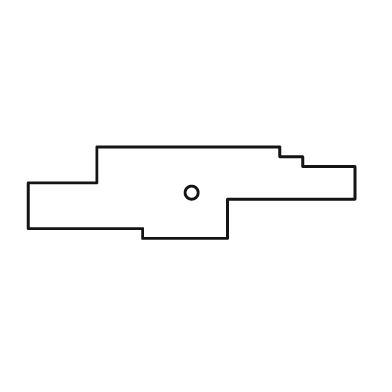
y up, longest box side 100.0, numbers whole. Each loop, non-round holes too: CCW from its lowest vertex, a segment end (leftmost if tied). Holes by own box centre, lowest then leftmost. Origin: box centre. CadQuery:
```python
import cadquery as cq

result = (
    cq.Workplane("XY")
    .moveTo(-15.0, -14.0)
    .lineTo(11.0, -14.0)
    .lineTo(11.0, -2.0)
    .lineTo(50.0, -2.0)
    .lineTo(50.0, 8.0)
    .lineTo(34.0, 8.0)
    .lineTo(34.0, 11.0)
    .lineTo(27.0, 11.0)
    .lineTo(27.0, 14.0)
    .lineTo(-29.0, 14.0)
    .lineTo(-29.0, 3.0)
    .lineTo(-50.0, 3.0)
    .lineTo(-50.0, -11.0)
    .lineTo(-15.0, -11.0)
    .close()
    .moveTo(0.0, 0.0)
    .circle(2.0)
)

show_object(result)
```